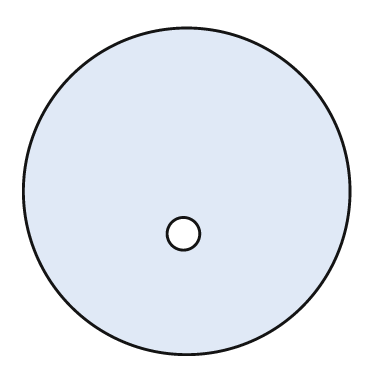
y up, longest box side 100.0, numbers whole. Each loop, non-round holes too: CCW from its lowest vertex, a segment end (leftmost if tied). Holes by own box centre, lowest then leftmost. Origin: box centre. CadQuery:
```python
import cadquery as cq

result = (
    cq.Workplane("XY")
    .moveTo(0.0, 0.0)
    .circle(50.0)
    .moveTo(-1.0, -13.0)
    .circle(5.0)
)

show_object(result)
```